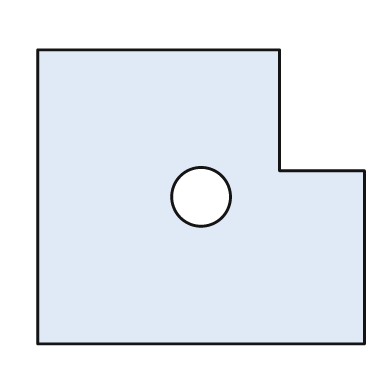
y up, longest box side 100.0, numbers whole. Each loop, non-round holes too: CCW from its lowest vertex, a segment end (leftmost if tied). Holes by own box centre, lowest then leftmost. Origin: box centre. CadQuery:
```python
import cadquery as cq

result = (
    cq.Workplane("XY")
    .moveTo(-50.0, -45.0)
    .lineTo(50.0, -45.0)
    .lineTo(50.0, 8.0)
    .lineTo(24.0, 8.0)
    .lineTo(24.0, 45.0)
    .lineTo(-50.0, 45.0)
    .close()
    .moveTo(0.0, 0.0)
    .circle(9.0)
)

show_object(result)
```